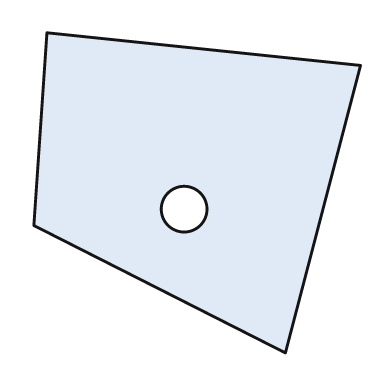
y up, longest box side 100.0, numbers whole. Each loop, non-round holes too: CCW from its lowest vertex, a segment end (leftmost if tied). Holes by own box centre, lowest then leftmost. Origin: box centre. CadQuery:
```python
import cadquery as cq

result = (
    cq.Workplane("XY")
    .moveTo(27.0, -49.0)
    .lineTo(50.0, 39.0)
    .lineTo(-46.0, 49.0)
    .lineTo(-50.0, -10.0)
    .close()
    .moveTo(-4.0, -5.0)
    .circle(7.0)
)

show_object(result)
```